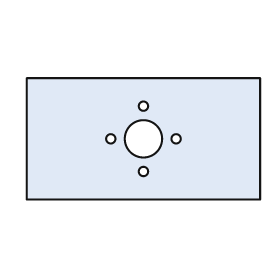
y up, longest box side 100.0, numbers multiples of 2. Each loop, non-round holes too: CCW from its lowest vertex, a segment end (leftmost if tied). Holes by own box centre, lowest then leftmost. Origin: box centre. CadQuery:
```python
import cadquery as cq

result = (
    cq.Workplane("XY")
    .moveTo(-50.0, -26.0)
    .lineTo(50.0, -26.0)
    .lineTo(50.0, 26.0)
    .lineTo(-50.0, 26.0)
    .close()
    .moveTo(0.0, -14.0)
    .circle(2.0)
    .moveTo(-14.0, 0.0)
    .circle(2.0)
    .moveTo(0.0, 0.0)
    .circle(8.0)
    .moveTo(14.0, 0.0)
    .circle(2.0)
    .moveTo(0.0, 14.0)
    .circle(2.0)
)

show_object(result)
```